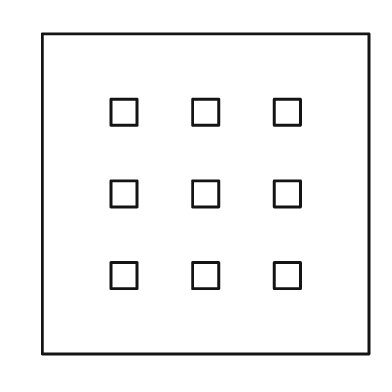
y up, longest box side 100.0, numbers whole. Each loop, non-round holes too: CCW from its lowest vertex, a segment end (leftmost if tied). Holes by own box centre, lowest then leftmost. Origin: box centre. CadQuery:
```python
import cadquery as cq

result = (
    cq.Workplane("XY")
    .moveTo(-50.0, -49.0)
    .lineTo(50.0, -49.0)
    .lineTo(50.0, 49.0)
    .lineTo(-50.0, 49.0)
    .close()
    .moveTo(-29.0, -29.0)
    .lineTo(-21.0, -29.0)
    .lineTo(-21.0, -21.0)
    .lineTo(-29.0, -21.0)
    .close()
    .moveTo(-4.0, -29.0)
    .lineTo(4.0, -29.0)
    .lineTo(4.0, -21.0)
    .lineTo(-4.0, -21.0)
    .close()
    .moveTo(21.0, -29.0)
    .lineTo(29.0, -29.0)
    .lineTo(29.0, -21.0)
    .lineTo(21.0, -21.0)
    .close()
    .moveTo(-29.0, -4.0)
    .lineTo(-21.0, -4.0)
    .lineTo(-21.0, 4.0)
    .lineTo(-29.0, 4.0)
    .close()
    .moveTo(-4.0, -4.0)
    .lineTo(4.0, -4.0)
    .lineTo(4.0, 4.0)
    .lineTo(-4.0, 4.0)
    .close()
    .moveTo(21.0, -4.0)
    .lineTo(29.0, -4.0)
    .lineTo(29.0, 4.0)
    .lineTo(21.0, 4.0)
    .close()
    .moveTo(-29.0, 21.0)
    .lineTo(-21.0, 21.0)
    .lineTo(-21.0, 29.0)
    .lineTo(-29.0, 29.0)
    .close()
    .moveTo(-4.0, 21.0)
    .lineTo(4.0, 21.0)
    .lineTo(4.0, 29.0)
    .lineTo(-4.0, 29.0)
    .close()
    .moveTo(21.0, 21.0)
    .lineTo(29.0, 21.0)
    .lineTo(29.0, 29.0)
    .lineTo(21.0, 29.0)
    .close()
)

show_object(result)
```